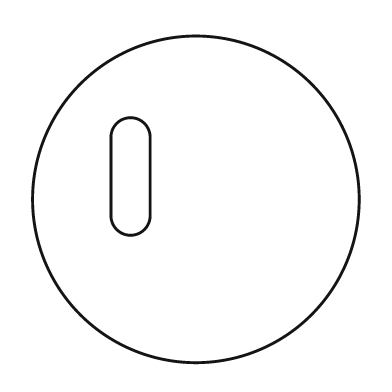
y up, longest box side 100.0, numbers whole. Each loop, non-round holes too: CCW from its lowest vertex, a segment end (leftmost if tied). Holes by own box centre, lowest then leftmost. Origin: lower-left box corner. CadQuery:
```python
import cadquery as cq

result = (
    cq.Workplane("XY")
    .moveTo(50.0, 50.0)
    .circle(50.0)
    .moveTo(24.0, 45.0)
    .threePointArc((30.0, 39.0), (36.0, 45.0))
    .lineTo(36.0, 69.0)
    .threePointArc((30.0, 75.0), (24.0, 69.0))
    .close()
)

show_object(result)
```